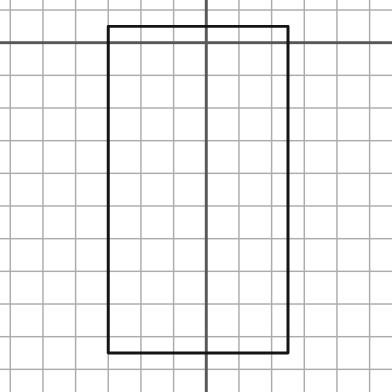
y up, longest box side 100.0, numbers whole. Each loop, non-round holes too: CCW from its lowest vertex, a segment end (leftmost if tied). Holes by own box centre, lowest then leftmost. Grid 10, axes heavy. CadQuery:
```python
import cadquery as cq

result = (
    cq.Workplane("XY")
    .moveTo(-30.0, -95.0)
    .lineTo(25.0, -95.0)
    .lineTo(25.0, 5.0)
    .lineTo(-30.0, 5.0)
    .close()
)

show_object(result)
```